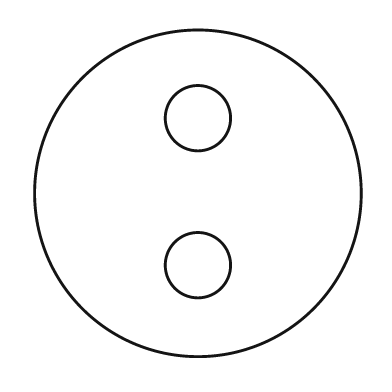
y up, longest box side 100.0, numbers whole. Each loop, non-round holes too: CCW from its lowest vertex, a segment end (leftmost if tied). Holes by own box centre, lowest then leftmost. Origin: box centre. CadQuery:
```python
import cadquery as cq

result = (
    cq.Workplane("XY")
    .moveTo(0.0, 0.0)
    .circle(50.0)
    .moveTo(0.0, -22.0)
    .circle(10.0)
    .moveTo(0.0, 23.0)
    .circle(10.0)
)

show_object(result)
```